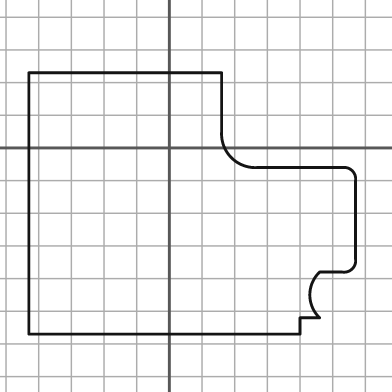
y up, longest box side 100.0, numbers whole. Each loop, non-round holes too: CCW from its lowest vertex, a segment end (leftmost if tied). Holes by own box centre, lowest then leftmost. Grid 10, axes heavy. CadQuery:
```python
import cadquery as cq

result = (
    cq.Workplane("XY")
    .moveTo(-43.0, -57.0)
    .lineTo(40.0, -57.0)
    .lineTo(40.0, -52.0)
    .lineTo(46.0, -52.0)
    .threePointArc((43.0, -45.0), (46.0, -38.0))
    .lineTo(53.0, -38.0)
    .threePointArc((56.0, -37.0), (57.0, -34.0))
    .lineTo(57.0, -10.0)
    .threePointArc((56.0, -7.0), (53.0, -6.0))
    .lineTo(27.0, -6.0)
    .threePointArc((19.0, -3.0), (16.0, 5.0))
    .lineTo(16.0, 23.0)
    .lineTo(-43.0, 23.0)
    .close()
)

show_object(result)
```